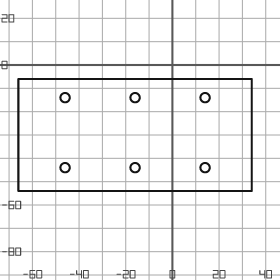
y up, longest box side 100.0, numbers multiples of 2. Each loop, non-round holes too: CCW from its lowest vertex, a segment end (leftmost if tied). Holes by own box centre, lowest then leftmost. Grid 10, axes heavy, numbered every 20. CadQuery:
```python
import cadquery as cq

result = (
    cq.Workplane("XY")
    .moveTo(-66.0, -54.0)
    .lineTo(34.0, -54.0)
    .lineTo(34.0, -6.0)
    .lineTo(-66.0, -6.0)
    .close()
    .moveTo(-46.0, -44.0)
    .circle(2.0)
    .moveTo(-16.0, -44.0)
    .circle(2.0)
    .moveTo(14.0, -44.0)
    .circle(2.0)
    .moveTo(-46.0, -14.0)
    .circle(2.0)
    .moveTo(-16.0, -14.0)
    .circle(2.0)
    .moveTo(14.0, -14.0)
    .circle(2.0)
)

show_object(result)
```